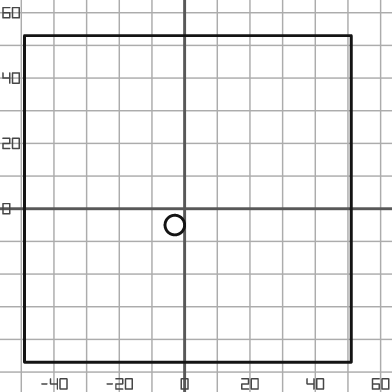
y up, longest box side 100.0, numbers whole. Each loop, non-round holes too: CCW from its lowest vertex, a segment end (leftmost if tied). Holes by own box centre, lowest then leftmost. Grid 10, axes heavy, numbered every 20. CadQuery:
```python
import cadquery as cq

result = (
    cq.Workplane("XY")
    .moveTo(-49.0, -47.0)
    .lineTo(51.0, -47.0)
    .lineTo(51.0, 53.0)
    .lineTo(-49.0, 53.0)
    .close()
    .moveTo(-3.0, -5.0)
    .circle(3.0)
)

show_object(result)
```